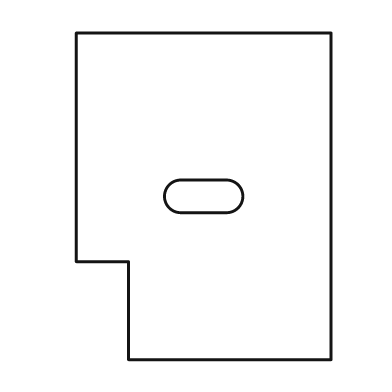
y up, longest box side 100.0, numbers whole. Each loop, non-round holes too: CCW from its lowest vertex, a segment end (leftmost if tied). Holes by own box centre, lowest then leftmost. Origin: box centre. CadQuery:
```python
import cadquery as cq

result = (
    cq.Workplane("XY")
    .moveTo(-23.0, -50.0)
    .lineTo(39.0, -50.0)
    .lineTo(39.0, 50.0)
    .lineTo(-39.0, 50.0)
    .lineTo(-39.0, -20.0)
    .lineTo(-23.0, -20.0)
    .close()
    .moveTo(-7.0, -5.0)
    .lineTo(7.0, -5.0)
    .threePointArc((12.0, 0.0), (7.0, 5.0))
    .lineTo(-7.0, 5.0)
    .threePointArc((-12.0, 0.0), (-7.0, -5.0))
    .close()
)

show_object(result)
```